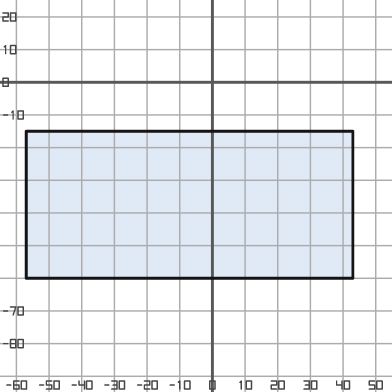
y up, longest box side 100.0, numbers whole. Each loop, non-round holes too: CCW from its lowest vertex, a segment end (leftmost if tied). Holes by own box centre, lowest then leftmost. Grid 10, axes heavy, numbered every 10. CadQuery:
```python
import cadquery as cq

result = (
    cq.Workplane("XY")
    .moveTo(-57.0, -60.0)
    .lineTo(43.0, -60.0)
    .lineTo(43.0, -15.0)
    .lineTo(-57.0, -15.0)
    .close()
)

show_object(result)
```